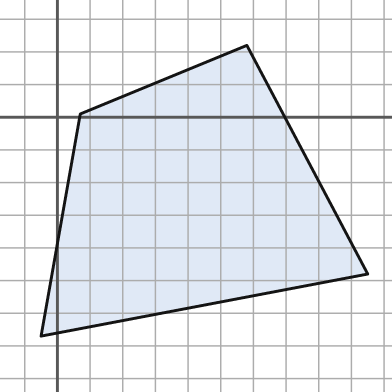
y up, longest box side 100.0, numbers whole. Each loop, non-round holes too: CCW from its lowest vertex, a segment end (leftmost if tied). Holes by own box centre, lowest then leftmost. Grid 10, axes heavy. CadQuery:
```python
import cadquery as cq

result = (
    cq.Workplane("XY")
    .moveTo(-5.0, -67.0)
    .lineTo(95.0, -48.0)
    .lineTo(58.0, 22.0)
    .lineTo(7.0, 1.0)
    .close()
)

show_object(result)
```